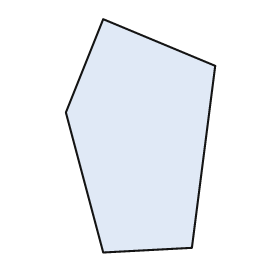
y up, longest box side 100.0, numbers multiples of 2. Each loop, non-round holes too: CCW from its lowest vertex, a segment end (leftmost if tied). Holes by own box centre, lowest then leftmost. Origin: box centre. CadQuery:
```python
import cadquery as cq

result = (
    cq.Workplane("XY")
    .moveTo(-16.0, -50.0)
    .lineTo(22.0, -48.0)
    .lineTo(32.0, 30.0)
    .lineTo(-16.0, 50.0)
    .lineTo(-32.0, 10.0)
    .close()
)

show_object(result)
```